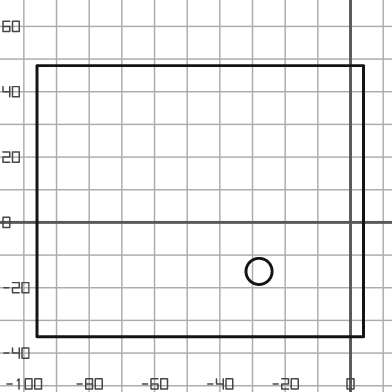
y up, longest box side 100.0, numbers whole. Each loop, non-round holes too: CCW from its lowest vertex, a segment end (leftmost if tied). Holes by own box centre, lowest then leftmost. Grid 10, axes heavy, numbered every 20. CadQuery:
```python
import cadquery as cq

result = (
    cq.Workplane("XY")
    .moveTo(-96.0, -35.0)
    .lineTo(4.0, -35.0)
    .lineTo(4.0, 48.0)
    .lineTo(-96.0, 48.0)
    .close()
    .moveTo(-28.0, -15.0)
    .circle(4.0)
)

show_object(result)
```